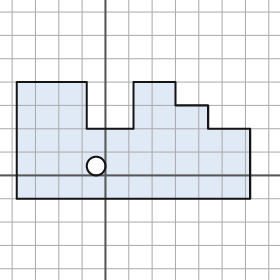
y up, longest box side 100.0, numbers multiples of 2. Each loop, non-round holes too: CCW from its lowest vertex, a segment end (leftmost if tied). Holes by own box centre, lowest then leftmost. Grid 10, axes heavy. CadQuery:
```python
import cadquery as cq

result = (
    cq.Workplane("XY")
    .moveTo(-38.0, -10.0)
    .lineTo(62.0, -10.0)
    .lineTo(62.0, 20.0)
    .lineTo(44.0, 20.0)
    .lineTo(44.0, 30.0)
    .lineTo(30.0, 30.0)
    .lineTo(30.0, 40.0)
    .lineTo(12.0, 40.0)
    .lineTo(12.0, 20.0)
    .lineTo(-8.0, 20.0)
    .lineTo(-8.0, 40.0)
    .lineTo(-38.0, 40.0)
    .close()
    .moveTo(-4.0, 4.0)
    .circle(4.0)
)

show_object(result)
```